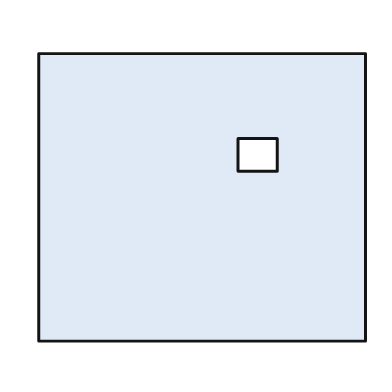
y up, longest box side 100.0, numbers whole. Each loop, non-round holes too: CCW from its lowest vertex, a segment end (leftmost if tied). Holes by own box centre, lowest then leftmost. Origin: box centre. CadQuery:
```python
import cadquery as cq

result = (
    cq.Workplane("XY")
    .moveTo(-50.0, -44.0)
    .lineTo(50.0, -44.0)
    .lineTo(50.0, 44.0)
    .lineTo(-50.0, 44.0)
    .close()
    .moveTo(11.0, 8.0)
    .lineTo(23.0, 8.0)
    .lineTo(23.0, 18.0)
    .lineTo(11.0, 18.0)
    .close()
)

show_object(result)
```